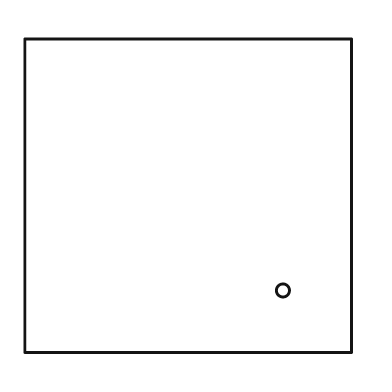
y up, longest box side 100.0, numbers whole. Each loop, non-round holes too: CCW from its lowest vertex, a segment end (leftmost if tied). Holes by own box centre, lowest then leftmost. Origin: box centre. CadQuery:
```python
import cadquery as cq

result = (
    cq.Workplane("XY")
    .moveTo(-50.0, -48.0)
    .lineTo(50.0, -48.0)
    .lineTo(50.0, 48.0)
    .lineTo(-50.0, 48.0)
    .close()
    .moveTo(29.0, -29.0)
    .circle(2.0)
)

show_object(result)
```